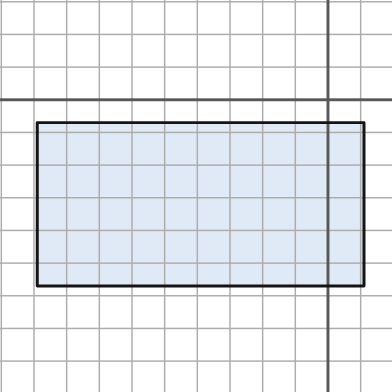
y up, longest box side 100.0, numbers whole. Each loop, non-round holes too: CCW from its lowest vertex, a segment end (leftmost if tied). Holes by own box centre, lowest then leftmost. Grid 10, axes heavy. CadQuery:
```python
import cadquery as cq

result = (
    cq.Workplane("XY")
    .moveTo(-89.0, -57.0)
    .lineTo(11.0, -57.0)
    .lineTo(11.0, -7.0)
    .lineTo(-89.0, -7.0)
    .close()
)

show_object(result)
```